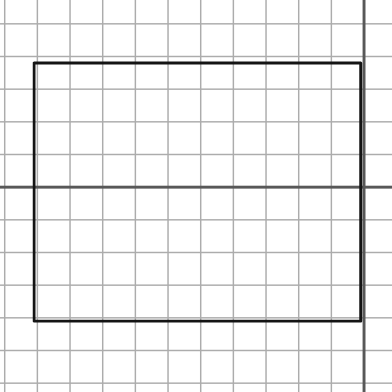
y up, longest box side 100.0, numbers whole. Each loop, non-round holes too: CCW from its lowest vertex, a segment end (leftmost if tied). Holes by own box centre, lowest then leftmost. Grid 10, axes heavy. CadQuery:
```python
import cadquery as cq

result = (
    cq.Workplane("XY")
    .moveTo(-101.0, -41.0)
    .lineTo(-1.0, -41.0)
    .lineTo(-1.0, 38.0)
    .lineTo(-101.0, 38.0)
    .close()
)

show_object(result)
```